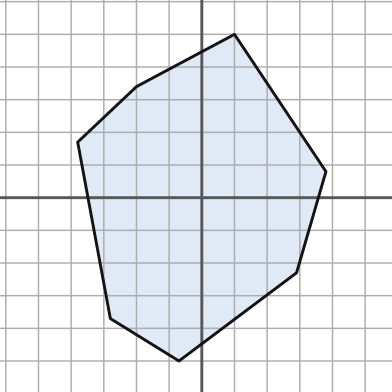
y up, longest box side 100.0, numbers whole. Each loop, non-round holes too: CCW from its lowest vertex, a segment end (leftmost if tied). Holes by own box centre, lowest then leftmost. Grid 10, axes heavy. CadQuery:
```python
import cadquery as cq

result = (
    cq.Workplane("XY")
    .moveTo(-7.0, -50.0)
    .lineTo(29.0, -23.0)
    .lineTo(38.0, 8.0)
    .lineTo(10.0, 50.0)
    .lineTo(-20.0, 34.0)
    .lineTo(-38.0, 17.0)
    .lineTo(-28.0, -37.0)
    .close()
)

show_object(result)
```